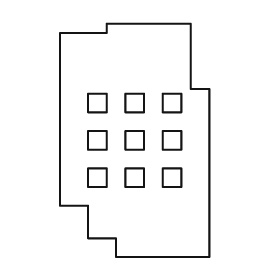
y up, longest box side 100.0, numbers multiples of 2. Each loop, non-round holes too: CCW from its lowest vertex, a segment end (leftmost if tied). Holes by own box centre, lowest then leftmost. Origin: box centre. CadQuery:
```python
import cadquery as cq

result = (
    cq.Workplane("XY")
    .moveTo(-8.0, -50.0)
    .lineTo(32.0, -50.0)
    .lineTo(32.0, 22.0)
    .lineTo(24.0, 22.0)
    .lineTo(24.0, 50.0)
    .lineTo(-12.0, 50.0)
    .lineTo(-12.0, 46.0)
    .lineTo(-32.0, 46.0)
    .lineTo(-32.0, -28.0)
    .lineTo(-20.0, -28.0)
    .lineTo(-20.0, -42.0)
    .lineTo(-8.0, -42.0)
    .close()
    .moveTo(-20.0, -20.0)
    .lineTo(-12.0, -20.0)
    .lineTo(-12.0, -12.0)
    .lineTo(-20.0, -12.0)
    .close()
    .moveTo(-4.0, -20.0)
    .lineTo(4.0, -20.0)
    .lineTo(4.0, -12.0)
    .lineTo(-4.0, -12.0)
    .close()
    .moveTo(12.0, -20.0)
    .lineTo(20.0, -20.0)
    .lineTo(20.0, -12.0)
    .lineTo(12.0, -12.0)
    .close()
    .moveTo(-20.0, -4.0)
    .lineTo(-12.0, -4.0)
    .lineTo(-12.0, 4.0)
    .lineTo(-20.0, 4.0)
    .close()
    .moveTo(-4.0, -4.0)
    .lineTo(4.0, -4.0)
    .lineTo(4.0, 4.0)
    .lineTo(-4.0, 4.0)
    .close()
    .moveTo(12.0, -4.0)
    .lineTo(20.0, -4.0)
    .lineTo(20.0, 4.0)
    .lineTo(12.0, 4.0)
    .close()
    .moveTo(-20.0, 12.0)
    .lineTo(-12.0, 12.0)
    .lineTo(-12.0, 20.0)
    .lineTo(-20.0, 20.0)
    .close()
    .moveTo(-4.0, 12.0)
    .lineTo(4.0, 12.0)
    .lineTo(4.0, 20.0)
    .lineTo(-4.0, 20.0)
    .close()
    .moveTo(12.0, 12.0)
    .lineTo(20.0, 12.0)
    .lineTo(20.0, 20.0)
    .lineTo(12.0, 20.0)
    .close()
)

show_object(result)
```